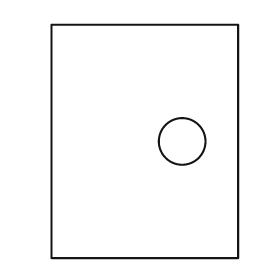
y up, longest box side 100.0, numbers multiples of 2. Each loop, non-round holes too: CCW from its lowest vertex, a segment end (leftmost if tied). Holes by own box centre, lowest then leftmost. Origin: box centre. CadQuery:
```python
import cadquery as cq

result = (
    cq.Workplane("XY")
    .moveTo(-40.0, -50.0)
    .lineTo(40.0, -50.0)
    .lineTo(40.0, 50.0)
    .lineTo(-40.0, 50.0)
    .close()
    .moveTo(16.0, 0.0)
    .circle(10.0)
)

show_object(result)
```